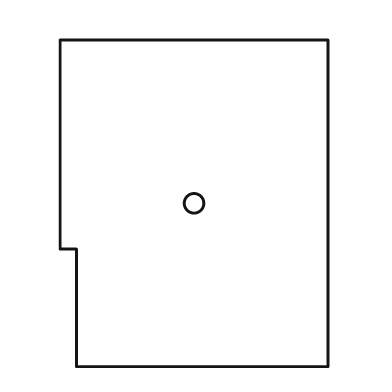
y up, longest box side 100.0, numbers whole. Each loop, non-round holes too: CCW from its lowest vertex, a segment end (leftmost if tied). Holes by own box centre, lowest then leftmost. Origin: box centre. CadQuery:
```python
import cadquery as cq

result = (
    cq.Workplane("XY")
    .moveTo(-36.0, -50.0)
    .lineTo(41.0, -50.0)
    .lineTo(41.0, 50.0)
    .lineTo(-41.0, 50.0)
    .lineTo(-41.0, -14.0)
    .lineTo(-36.0, -14.0)
    .close()
    .moveTo(0.0, 0.0)
    .circle(3.0)
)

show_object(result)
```